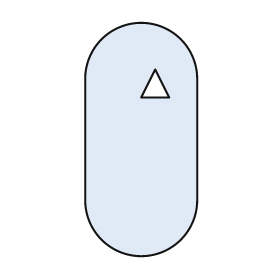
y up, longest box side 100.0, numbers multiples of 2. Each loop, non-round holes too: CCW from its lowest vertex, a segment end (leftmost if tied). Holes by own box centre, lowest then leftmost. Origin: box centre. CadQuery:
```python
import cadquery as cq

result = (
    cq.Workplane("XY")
    .moveTo(-24.0, -26.0)
    .threePointArc((0.0, -50.0), (24.0, -26.0))
    .lineTo(24.0, 26.0)
    .threePointArc((0.0, 50.0), (-24.0, 26.0))
    .close()
    .moveTo(0.0, 18.0)
    .lineTo(12.0, 18.0)
    .lineTo(6.0, 30.0)
    .close()
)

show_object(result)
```